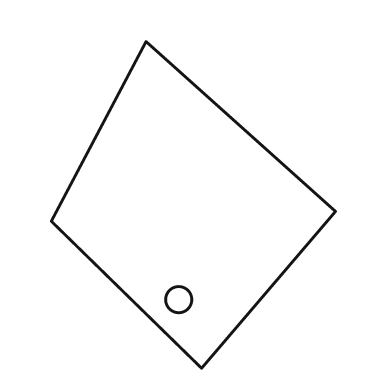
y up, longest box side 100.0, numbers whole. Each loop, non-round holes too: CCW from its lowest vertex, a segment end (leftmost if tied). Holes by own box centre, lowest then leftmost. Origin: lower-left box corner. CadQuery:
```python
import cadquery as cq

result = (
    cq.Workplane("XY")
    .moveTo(46.0, 0.0)
    .lineTo(87.0, 48.0)
    .lineTo(29.0, 100.0)
    .lineTo(0.0, 45.0)
    .close()
    .moveTo(39.0, 21.0)
    .circle(4.0)
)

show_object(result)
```